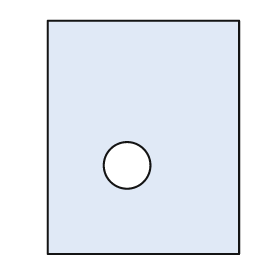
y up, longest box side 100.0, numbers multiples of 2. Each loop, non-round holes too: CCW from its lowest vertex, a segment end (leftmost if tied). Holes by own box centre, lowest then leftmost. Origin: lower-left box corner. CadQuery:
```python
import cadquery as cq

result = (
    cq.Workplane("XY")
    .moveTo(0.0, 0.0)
    .lineTo(82.0, 0.0)
    .lineTo(82.0, 100.0)
    .lineTo(0.0, 100.0)
    .close()
    .moveTo(34.0, 38.0)
    .circle(10.0)
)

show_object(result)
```